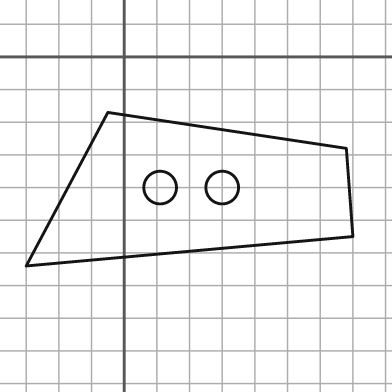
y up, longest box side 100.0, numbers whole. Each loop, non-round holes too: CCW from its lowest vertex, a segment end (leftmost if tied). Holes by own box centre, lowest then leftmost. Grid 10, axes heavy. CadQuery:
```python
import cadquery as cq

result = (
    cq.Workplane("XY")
    .moveTo(-30.0, -64.0)
    .lineTo(70.0, -55.0)
    .lineTo(68.0, -28.0)
    .lineTo(-5.0, -17.0)
    .close()
    .moveTo(11.0, -40.0)
    .circle(5.0)
    .moveTo(30.0, -40.0)
    .circle(5.0)
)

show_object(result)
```